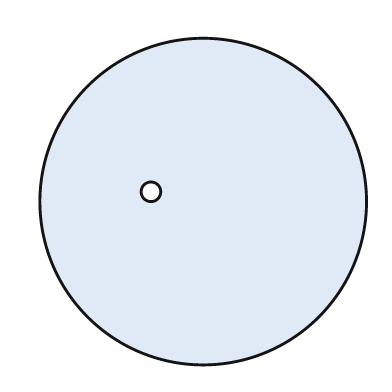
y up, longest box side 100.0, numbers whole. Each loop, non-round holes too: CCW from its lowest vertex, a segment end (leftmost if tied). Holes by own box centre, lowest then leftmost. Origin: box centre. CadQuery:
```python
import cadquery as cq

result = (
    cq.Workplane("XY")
    .moveTo(0.0, 0.0)
    .circle(50.0)
    .moveTo(-16.0, 3.0)
    .circle(3.0)
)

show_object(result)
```